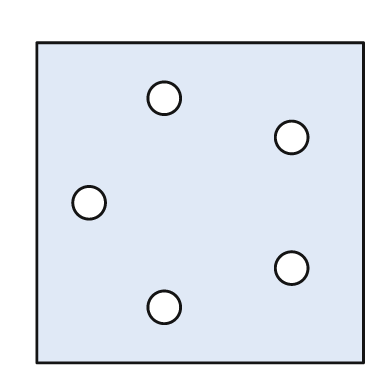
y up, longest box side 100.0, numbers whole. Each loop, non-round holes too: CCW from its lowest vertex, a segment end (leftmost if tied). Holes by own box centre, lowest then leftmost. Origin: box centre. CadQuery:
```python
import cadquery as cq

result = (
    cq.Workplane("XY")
    .moveTo(-50.0, -49.0)
    .lineTo(50.0, -49.0)
    .lineTo(50.0, 49.0)
    .lineTo(-50.0, 49.0)
    .close()
    .moveTo(-11.0, -32.0)
    .circle(5.0)
    .moveTo(28.0, -20.0)
    .circle(5.0)
    .moveTo(-34.0, 0.0)
    .circle(5.0)
    .moveTo(28.0, 20.0)
    .circle(5.0)
    .moveTo(-11.0, 32.0)
    .circle(5.0)
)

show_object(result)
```